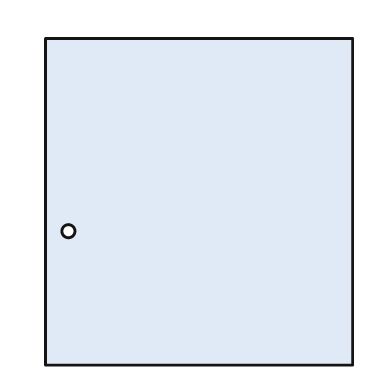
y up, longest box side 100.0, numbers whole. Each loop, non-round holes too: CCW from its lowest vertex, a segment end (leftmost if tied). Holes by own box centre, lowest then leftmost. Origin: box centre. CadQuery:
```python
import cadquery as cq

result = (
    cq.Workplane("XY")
    .moveTo(-47.0, -50.0)
    .lineTo(47.0, -50.0)
    .lineTo(47.0, 50.0)
    .lineTo(-47.0, 50.0)
    .close()
    .moveTo(-40.0, -9.0)
    .circle(2.0)
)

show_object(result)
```